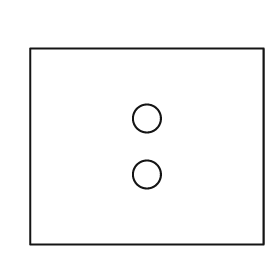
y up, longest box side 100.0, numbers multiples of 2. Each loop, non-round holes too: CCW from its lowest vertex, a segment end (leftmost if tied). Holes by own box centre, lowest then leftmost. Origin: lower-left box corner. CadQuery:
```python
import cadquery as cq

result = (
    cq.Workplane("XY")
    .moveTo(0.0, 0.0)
    .lineTo(100.0, 0.0)
    .lineTo(100.0, 84.0)
    .lineTo(0.0, 84.0)
    .close()
    .moveTo(50.0, 30.0)
    .circle(6.0)
    .moveTo(50.0, 54.0)
    .circle(6.0)
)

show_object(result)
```